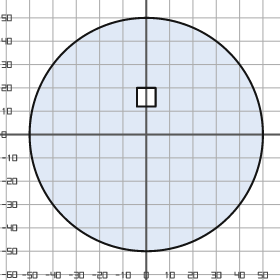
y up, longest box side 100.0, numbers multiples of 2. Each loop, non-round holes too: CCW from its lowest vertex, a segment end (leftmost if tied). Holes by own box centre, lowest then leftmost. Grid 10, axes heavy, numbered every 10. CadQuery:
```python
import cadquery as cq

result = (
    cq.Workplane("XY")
    .moveTo(0.0, 0.0)
    .circle(50.0)
    .moveTo(-4.0, 12.0)
    .lineTo(4.0, 12.0)
    .lineTo(4.0, 20.0)
    .lineTo(-4.0, 20.0)
    .close()
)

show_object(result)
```